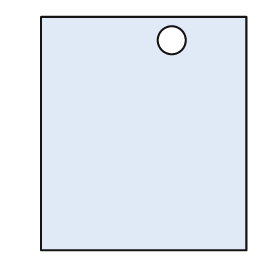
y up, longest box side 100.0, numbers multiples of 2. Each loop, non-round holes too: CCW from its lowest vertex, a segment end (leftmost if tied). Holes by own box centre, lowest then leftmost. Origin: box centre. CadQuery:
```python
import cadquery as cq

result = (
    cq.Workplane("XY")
    .moveTo(-44.0, -50.0)
    .lineTo(44.0, -50.0)
    .lineTo(44.0, 50.0)
    .lineTo(-44.0, 50.0)
    .close()
    .moveTo(12.0, 40.0)
    .circle(6.0)
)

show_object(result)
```